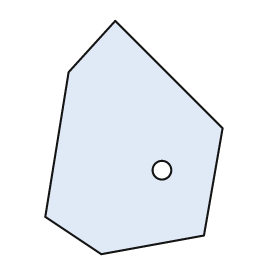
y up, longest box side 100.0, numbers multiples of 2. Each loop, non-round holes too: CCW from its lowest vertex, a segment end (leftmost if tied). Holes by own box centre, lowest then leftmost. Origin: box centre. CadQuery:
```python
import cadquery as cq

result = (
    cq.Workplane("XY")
    .moveTo(-14.0, -50.0)
    .lineTo(30.0, -42.0)
    .lineTo(38.0, 4.0)
    .lineTo(-8.0, 50.0)
    .lineTo(-28.0, 28.0)
    .lineTo(-38.0, -34.0)
    .close()
    .moveTo(12.0, -14.0)
    .circle(4.0)
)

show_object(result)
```